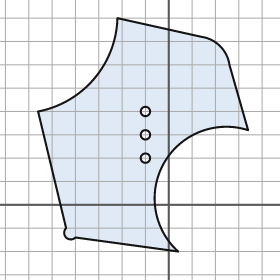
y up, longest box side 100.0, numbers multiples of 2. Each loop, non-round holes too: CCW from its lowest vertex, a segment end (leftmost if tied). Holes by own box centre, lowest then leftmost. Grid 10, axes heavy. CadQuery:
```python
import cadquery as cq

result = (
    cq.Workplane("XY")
    .moveTo(4.0, -20.0)
    .threePointArc((-2.0, 18.0), (34.0, 32.0))
    .lineTo(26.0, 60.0)
    .threePointArc((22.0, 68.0), (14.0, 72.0))
    .lineTo(-22.0, 80.0)
    .threePointArc((-32.0, 54.0), (-56.0, 40.0))
    .lineTo(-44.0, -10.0)
    .threePointArc((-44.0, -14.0), (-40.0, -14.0))
    .close()
    .moveTo(-10.0, 20.0)
    .circle(2.0)
    .moveTo(-10.0, 30.0)
    .circle(2.0)
    .moveTo(-10.0, 40.0)
    .circle(2.0)
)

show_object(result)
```